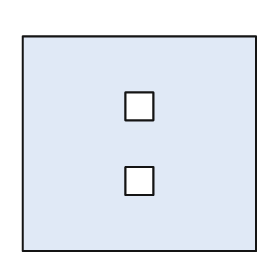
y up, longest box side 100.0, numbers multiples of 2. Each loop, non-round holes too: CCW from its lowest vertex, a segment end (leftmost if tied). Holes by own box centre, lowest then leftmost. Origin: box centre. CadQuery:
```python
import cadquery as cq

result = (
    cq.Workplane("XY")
    .moveTo(-50.0, -46.0)
    .lineTo(50.0, -46.0)
    .lineTo(50.0, 46.0)
    .lineTo(-50.0, 46.0)
    .close()
    .moveTo(-6.0, -22.0)
    .lineTo(6.0, -22.0)
    .lineTo(6.0, -10.0)
    .lineTo(-6.0, -10.0)
    .close()
    .moveTo(-6.0, 10.0)
    .lineTo(6.0, 10.0)
    .lineTo(6.0, 22.0)
    .lineTo(-6.0, 22.0)
    .close()
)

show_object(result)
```